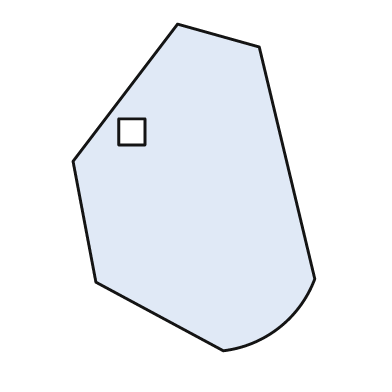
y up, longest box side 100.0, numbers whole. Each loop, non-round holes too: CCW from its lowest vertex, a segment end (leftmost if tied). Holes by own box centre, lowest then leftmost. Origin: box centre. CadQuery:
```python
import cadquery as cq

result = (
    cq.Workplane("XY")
    .moveTo(9.0, -50.0)
    .threePointArc((26.0, -43.0), (37.0, -28.0))
    .lineTo(20.0, 43.0)
    .lineTo(-5.0, 50.0)
    .lineTo(-37.0, 8.0)
    .lineTo(-30.0, -29.0)
    .close()
    .moveTo(-23.0, 13.0)
    .lineTo(-15.0, 13.0)
    .lineTo(-15.0, 21.0)
    .lineTo(-23.0, 21.0)
    .close()
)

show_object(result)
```